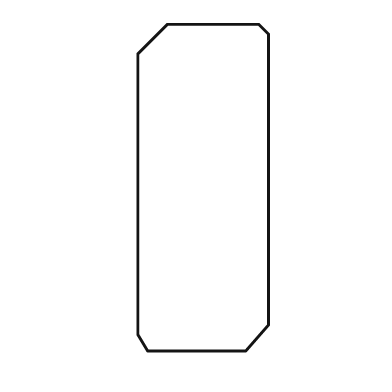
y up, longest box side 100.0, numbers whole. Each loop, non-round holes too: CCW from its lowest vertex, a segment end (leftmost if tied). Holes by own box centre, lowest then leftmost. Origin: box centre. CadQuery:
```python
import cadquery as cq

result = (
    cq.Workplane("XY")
    .moveTo(-17.0, -50.0)
    .lineTo(13.0, -50.0)
    .lineTo(20.0, -42.0)
    .lineTo(20.0, 47.0)
    .lineTo(17.0, 50.0)
    .lineTo(-11.0, 50.0)
    .lineTo(-20.0, 41.0)
    .lineTo(-20.0, -45.0)
    .close()
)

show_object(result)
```